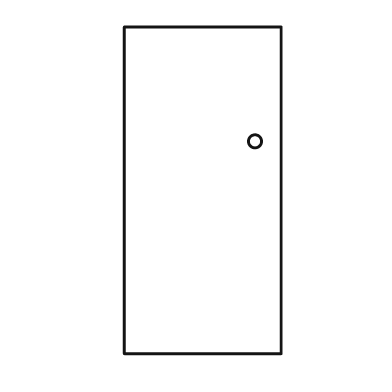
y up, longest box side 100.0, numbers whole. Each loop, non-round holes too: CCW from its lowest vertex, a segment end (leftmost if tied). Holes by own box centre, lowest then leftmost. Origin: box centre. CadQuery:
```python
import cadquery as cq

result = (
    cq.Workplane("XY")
    .moveTo(-24.0, -50.0)
    .lineTo(24.0, -50.0)
    .lineTo(24.0, 50.0)
    .lineTo(-24.0, 50.0)
    .close()
    .moveTo(16.0, 15.0)
    .circle(2.0)
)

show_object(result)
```